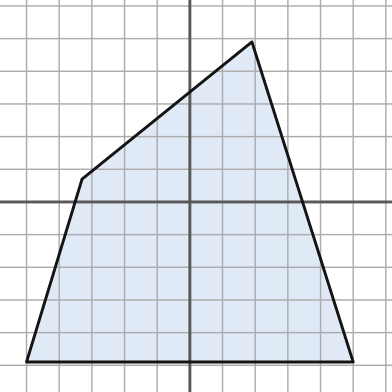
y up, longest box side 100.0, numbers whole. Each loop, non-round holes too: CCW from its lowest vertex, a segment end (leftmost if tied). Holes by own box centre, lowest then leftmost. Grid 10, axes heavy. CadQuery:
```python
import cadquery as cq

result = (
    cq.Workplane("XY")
    .moveTo(-50.0, -49.0)
    .lineTo(50.0, -49.0)
    .lineTo(19.0, 49.0)
    .lineTo(-33.0, 7.0)
    .close()
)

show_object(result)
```